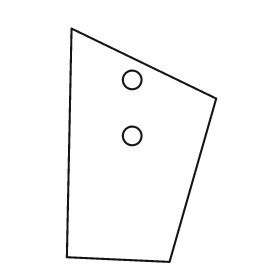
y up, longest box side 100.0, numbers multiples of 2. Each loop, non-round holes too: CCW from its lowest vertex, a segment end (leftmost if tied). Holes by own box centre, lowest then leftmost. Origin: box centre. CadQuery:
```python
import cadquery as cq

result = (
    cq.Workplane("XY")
    .moveTo(12.0, -50.0)
    .lineTo(32.0, 20.0)
    .lineTo(-30.0, 50.0)
    .lineTo(-32.0, -48.0)
    .close()
    .moveTo(-4.0, 4.0)
    .circle(4.0)
    .moveTo(-4.0, 28.0)
    .circle(4.0)
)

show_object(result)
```